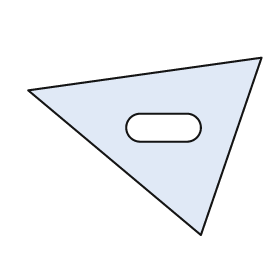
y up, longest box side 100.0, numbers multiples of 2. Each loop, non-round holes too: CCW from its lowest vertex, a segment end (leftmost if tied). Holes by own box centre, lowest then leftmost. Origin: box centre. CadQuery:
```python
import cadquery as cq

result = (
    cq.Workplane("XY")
    .moveTo(24.0, -38.0)
    .lineTo(50.0, 38.0)
    .lineTo(-50.0, 24.0)
    .close()
    .moveTo(-2.0, 2.0)
    .lineTo(18.0, 2.0)
    .threePointArc((24.0, 8.0), (18.0, 14.0))
    .lineTo(-2.0, 14.0)
    .threePointArc((-8.0, 8.0), (-2.0, 2.0))
    .close()
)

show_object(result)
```